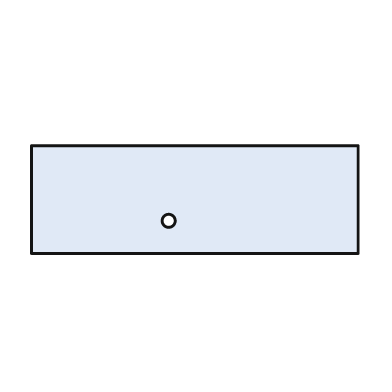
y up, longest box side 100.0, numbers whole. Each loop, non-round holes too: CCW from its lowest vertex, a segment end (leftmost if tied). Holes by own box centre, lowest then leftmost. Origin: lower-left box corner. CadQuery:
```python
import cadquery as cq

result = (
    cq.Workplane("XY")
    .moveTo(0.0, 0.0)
    .lineTo(100.0, 0.0)
    .lineTo(100.0, 33.0)
    .lineTo(0.0, 33.0)
    .close()
    .moveTo(42.0, 10.0)
    .circle(2.0)
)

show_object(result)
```